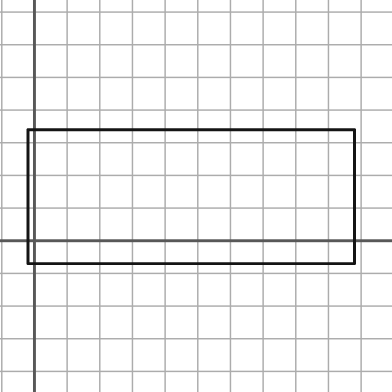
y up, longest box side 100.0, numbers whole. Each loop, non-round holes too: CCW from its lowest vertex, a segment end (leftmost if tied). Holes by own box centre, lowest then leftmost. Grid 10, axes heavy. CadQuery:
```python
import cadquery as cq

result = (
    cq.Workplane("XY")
    .moveTo(-2.0, -7.0)
    .lineTo(98.0, -7.0)
    .lineTo(98.0, 34.0)
    .lineTo(-2.0, 34.0)
    .close()
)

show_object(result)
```